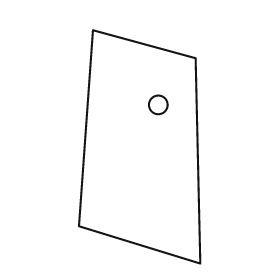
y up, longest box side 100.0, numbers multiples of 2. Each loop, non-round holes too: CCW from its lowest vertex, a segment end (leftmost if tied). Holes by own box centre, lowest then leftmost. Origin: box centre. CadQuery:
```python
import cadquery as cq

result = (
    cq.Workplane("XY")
    .moveTo(26.0, -50.0)
    .lineTo(24.0, 38.0)
    .lineTo(-20.0, 50.0)
    .lineTo(-26.0, -34.0)
    .close()
    .moveTo(8.0, 18.0)
    .circle(4.0)
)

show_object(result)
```